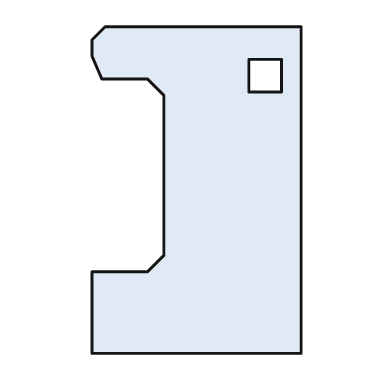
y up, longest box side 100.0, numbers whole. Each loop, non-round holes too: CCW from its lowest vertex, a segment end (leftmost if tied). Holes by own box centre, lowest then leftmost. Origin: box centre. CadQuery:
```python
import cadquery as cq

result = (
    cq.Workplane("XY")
    .moveTo(-32.0, -50.0)
    .lineTo(32.0, -50.0)
    .lineTo(32.0, 50.0)
    .lineTo(-28.0, 50.0)
    .lineTo(-32.0, 46.0)
    .lineTo(-32.0, 41.0)
    .lineTo(-29.0, 34.0)
    .lineTo(-15.0, 34.0)
    .lineTo(-10.0, 29.0)
    .lineTo(-10.0, -20.0)
    .lineTo(-15.0, -25.0)
    .lineTo(-32.0, -25.0)
    .close()
    .moveTo(16.0, 30.0)
    .lineTo(26.0, 30.0)
    .lineTo(26.0, 40.0)
    .lineTo(16.0, 40.0)
    .close()
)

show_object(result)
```